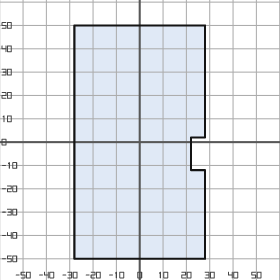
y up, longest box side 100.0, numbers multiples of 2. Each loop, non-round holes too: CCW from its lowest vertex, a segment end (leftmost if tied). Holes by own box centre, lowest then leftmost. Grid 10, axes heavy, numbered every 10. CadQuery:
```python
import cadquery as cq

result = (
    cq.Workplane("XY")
    .moveTo(-28.0, -50.0)
    .lineTo(28.0, -50.0)
    .lineTo(28.0, -12.0)
    .lineTo(22.0, -12.0)
    .lineTo(22.0, 2.0)
    .lineTo(28.0, 2.0)
    .lineTo(28.0, 50.0)
    .lineTo(-28.0, 50.0)
    .close()
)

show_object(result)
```